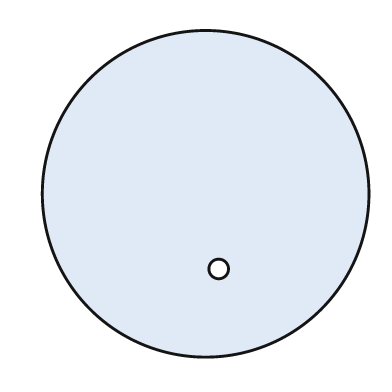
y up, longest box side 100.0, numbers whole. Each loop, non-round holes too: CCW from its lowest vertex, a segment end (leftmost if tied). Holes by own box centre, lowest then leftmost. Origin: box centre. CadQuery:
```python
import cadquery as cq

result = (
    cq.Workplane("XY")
    .moveTo(0.0, 0.0)
    .circle(50.0)
    .moveTo(4.0, -23.0)
    .circle(3.0)
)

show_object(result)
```